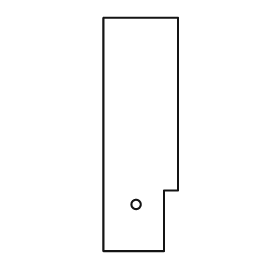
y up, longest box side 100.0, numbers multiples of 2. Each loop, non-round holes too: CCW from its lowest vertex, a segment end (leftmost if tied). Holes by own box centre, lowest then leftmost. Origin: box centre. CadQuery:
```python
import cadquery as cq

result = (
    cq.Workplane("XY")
    .moveTo(-16.0, -50.0)
    .lineTo(10.0, -50.0)
    .lineTo(10.0, -24.0)
    .lineTo(16.0, -24.0)
    .lineTo(16.0, 50.0)
    .lineTo(-16.0, 50.0)
    .close()
    .moveTo(-2.0, -30.0)
    .circle(2.0)
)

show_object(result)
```